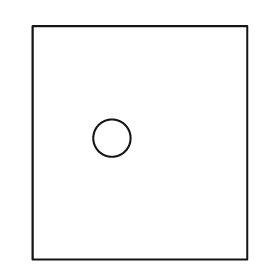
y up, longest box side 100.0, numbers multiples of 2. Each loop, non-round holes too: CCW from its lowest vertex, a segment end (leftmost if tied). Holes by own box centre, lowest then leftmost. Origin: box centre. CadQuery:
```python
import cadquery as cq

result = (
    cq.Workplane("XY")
    .moveTo(-46.0, -50.0)
    .lineTo(46.0, -50.0)
    .lineTo(46.0, 50.0)
    .lineTo(-46.0, 50.0)
    .close()
    .moveTo(-12.0, 2.0)
    .circle(8.0)
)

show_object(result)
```